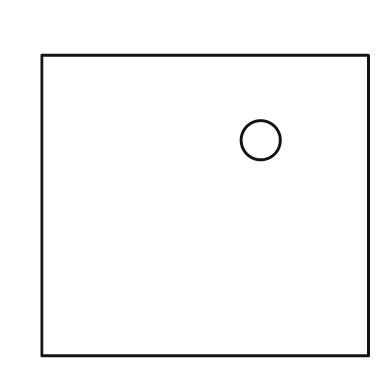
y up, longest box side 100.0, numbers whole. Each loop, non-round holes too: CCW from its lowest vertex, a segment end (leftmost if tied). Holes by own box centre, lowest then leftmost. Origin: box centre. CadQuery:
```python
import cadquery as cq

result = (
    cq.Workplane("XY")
    .moveTo(-50.0, -46.0)
    .lineTo(50.0, -46.0)
    .lineTo(50.0, 46.0)
    .lineTo(-50.0, 46.0)
    .close()
    .moveTo(17.0, 20.0)
    .circle(6.0)
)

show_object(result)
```